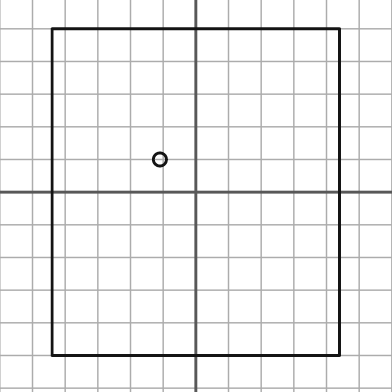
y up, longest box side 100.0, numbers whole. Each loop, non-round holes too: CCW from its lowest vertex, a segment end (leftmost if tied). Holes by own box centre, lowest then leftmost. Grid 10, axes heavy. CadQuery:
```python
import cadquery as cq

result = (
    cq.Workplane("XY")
    .moveTo(-44.0, -50.0)
    .lineTo(44.0, -50.0)
    .lineTo(44.0, 50.0)
    .lineTo(-44.0, 50.0)
    .close()
    .moveTo(-11.0, 10.0)
    .circle(2.0)
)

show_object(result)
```